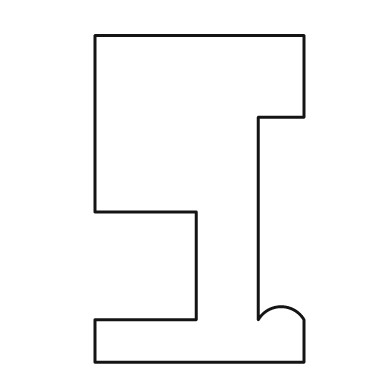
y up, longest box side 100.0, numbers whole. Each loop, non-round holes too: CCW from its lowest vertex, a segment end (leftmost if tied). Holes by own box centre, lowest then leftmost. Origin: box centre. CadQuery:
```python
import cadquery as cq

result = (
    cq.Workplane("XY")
    .moveTo(-32.0, -50.0)
    .lineTo(32.0, -50.0)
    .lineTo(32.0, -37.0)
    .threePointArc((25.0, -33.0), (18.0, -37.0))
    .lineTo(18.0, 25.0)
    .lineTo(32.0, 25.0)
    .lineTo(32.0, 50.0)
    .lineTo(-32.0, 50.0)
    .lineTo(-32.0, -4.0)
    .lineTo(-1.0, -4.0)
    .lineTo(-1.0, -37.0)
    .lineTo(-32.0, -37.0)
    .close()
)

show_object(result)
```